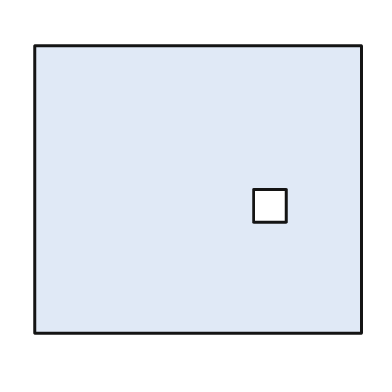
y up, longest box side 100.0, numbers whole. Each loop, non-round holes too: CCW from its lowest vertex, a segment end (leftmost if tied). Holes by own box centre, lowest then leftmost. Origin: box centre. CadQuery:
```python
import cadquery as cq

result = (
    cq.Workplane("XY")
    .moveTo(-50.0, -44.0)
    .lineTo(50.0, -44.0)
    .lineTo(50.0, 44.0)
    .lineTo(-50.0, 44.0)
    .close()
    .moveTo(17.0, -10.0)
    .lineTo(27.0, -10.0)
    .lineTo(27.0, 0.0)
    .lineTo(17.0, 0.0)
    .close()
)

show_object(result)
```